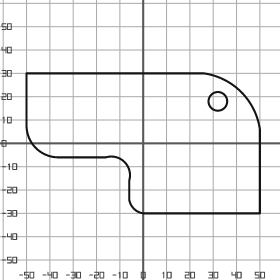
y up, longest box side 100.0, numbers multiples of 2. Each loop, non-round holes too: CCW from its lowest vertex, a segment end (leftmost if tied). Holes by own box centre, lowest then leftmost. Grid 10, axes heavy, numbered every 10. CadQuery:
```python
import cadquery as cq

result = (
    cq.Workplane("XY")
    .moveTo(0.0, -30.0)
    .lineTo(50.0, -30.0)
    .lineTo(50.0, 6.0)
    .threePointArc((42.0, 22.0), (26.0, 30.0))
    .lineTo(-50.0, 30.0)
    .lineTo(-50.0, 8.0)
    .threePointArc((-46.0, -2.0), (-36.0, -6.0))
    .lineTo(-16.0, -6.0)
    .threePointArc((-8.0, -8.0), (-6.0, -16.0))
    .lineTo(-6.0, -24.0)
    .threePointArc((-4.0, -28.0), (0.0, -30.0))
    .close()
    .moveTo(32.0, 18.0)
    .circle(4.0)
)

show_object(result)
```